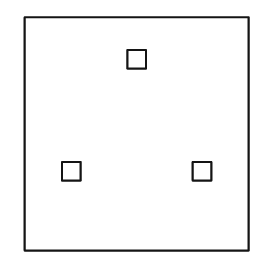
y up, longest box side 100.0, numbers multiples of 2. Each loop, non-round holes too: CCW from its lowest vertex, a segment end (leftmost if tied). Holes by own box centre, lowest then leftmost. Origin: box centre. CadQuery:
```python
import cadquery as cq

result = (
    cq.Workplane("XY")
    .moveTo(-48.0, -50.0)
    .lineTo(48.0, -50.0)
    .lineTo(48.0, 50.0)
    .lineTo(-48.0, 50.0)
    .close()
    .moveTo(-32.0, -20.0)
    .lineTo(-24.0, -20.0)
    .lineTo(-24.0, -12.0)
    .lineTo(-32.0, -12.0)
    .close()
    .moveTo(24.0, -20.0)
    .lineTo(32.0, -20.0)
    .lineTo(32.0, -12.0)
    .lineTo(24.0, -12.0)
    .close()
    .moveTo(-4.0, 28.0)
    .lineTo(4.0, 28.0)
    .lineTo(4.0, 36.0)
    .lineTo(-4.0, 36.0)
    .close()
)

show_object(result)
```